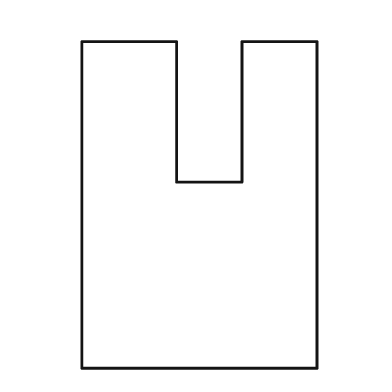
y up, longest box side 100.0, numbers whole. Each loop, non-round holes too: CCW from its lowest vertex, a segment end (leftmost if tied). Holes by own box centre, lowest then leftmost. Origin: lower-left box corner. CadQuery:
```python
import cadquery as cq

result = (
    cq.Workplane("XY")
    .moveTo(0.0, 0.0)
    .lineTo(72.0, 0.0)
    .lineTo(72.0, 100.0)
    .lineTo(49.0, 100.0)
    .lineTo(49.0, 57.0)
    .lineTo(29.0, 57.0)
    .lineTo(29.0, 100.0)
    .lineTo(0.0, 100.0)
    .close()
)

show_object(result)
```